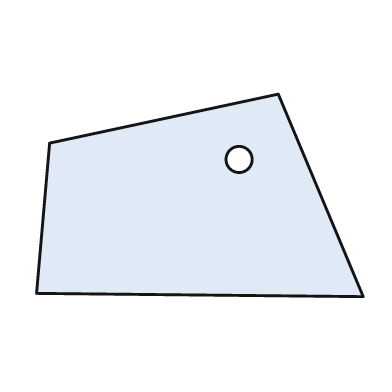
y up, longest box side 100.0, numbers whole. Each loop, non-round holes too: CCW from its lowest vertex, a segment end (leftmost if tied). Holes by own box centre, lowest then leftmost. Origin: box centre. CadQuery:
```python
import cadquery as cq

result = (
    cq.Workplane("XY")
    .moveTo(50.0, -31.0)
    .lineTo(24.0, 31.0)
    .lineTo(-46.0, 16.0)
    .lineTo(-50.0, -30.0)
    .close()
    .moveTo(12.0, 11.0)
    .circle(4.0)
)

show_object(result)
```